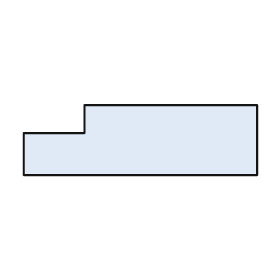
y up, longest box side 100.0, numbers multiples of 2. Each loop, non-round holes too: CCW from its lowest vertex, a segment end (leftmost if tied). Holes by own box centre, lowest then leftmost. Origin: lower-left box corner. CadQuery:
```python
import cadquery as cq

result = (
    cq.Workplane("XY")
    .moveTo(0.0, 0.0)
    .lineTo(100.0, 0.0)
    .lineTo(100.0, 30.0)
    .lineTo(26.0, 30.0)
    .lineTo(26.0, 18.0)
    .lineTo(0.0, 18.0)
    .close()
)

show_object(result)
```